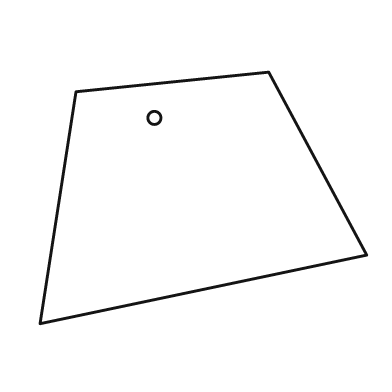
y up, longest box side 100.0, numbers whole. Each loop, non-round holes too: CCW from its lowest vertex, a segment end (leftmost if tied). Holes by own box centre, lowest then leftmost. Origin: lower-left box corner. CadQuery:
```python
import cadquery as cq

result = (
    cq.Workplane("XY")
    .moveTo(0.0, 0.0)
    .lineTo(100.0, 21.0)
    .lineTo(70.0, 77.0)
    .lineTo(11.0, 71.0)
    .close()
    .moveTo(35.0, 63.0)
    .circle(2.0)
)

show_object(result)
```